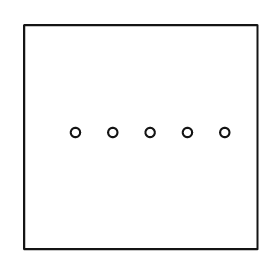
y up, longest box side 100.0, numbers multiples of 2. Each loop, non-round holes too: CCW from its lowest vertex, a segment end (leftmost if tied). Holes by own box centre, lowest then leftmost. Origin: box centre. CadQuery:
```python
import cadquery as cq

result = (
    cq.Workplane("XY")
    .moveTo(-50.0, -48.0)
    .lineTo(50.0, -48.0)
    .lineTo(50.0, 48.0)
    .lineTo(-50.0, 48.0)
    .close()
    .moveTo(-28.0, 2.0)
    .circle(2.0)
    .moveTo(-12.0, 2.0)
    .circle(2.0)
    .moveTo(4.0, 2.0)
    .circle(2.0)
    .moveTo(20.0, 2.0)
    .circle(2.0)
    .moveTo(36.0, 2.0)
    .circle(2.0)
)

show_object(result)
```